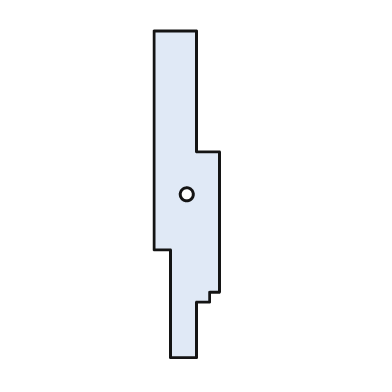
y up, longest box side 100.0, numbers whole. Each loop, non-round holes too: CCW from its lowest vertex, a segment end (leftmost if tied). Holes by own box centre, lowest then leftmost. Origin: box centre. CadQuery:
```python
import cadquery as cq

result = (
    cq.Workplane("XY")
    .moveTo(-5.0, -50.0)
    .lineTo(3.0, -50.0)
    .lineTo(3.0, -33.0)
    .lineTo(7.0, -33.0)
    .lineTo(7.0, -30.0)
    .lineTo(10.0, -30.0)
    .lineTo(10.0, 13.0)
    .lineTo(3.0, 13.0)
    .lineTo(3.0, 50.0)
    .lineTo(-10.0, 50.0)
    .lineTo(-10.0, -17.0)
    .lineTo(-5.0, -17.0)
    .close()
    .moveTo(0.0, 0.0)
    .circle(2.0)
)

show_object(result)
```